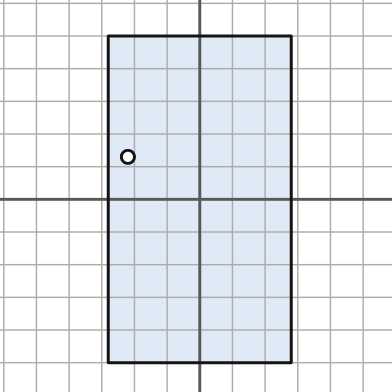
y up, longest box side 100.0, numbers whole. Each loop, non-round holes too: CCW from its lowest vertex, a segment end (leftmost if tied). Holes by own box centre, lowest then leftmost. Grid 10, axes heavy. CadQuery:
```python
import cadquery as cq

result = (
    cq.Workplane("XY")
    .moveTo(-28.0, -50.0)
    .lineTo(28.0, -50.0)
    .lineTo(28.0, 50.0)
    .lineTo(-28.0, 50.0)
    .close()
    .moveTo(-22.0, 13.0)
    .circle(2.0)
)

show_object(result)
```